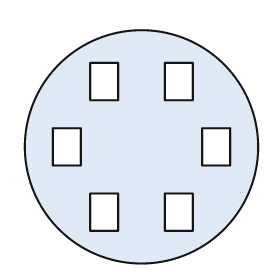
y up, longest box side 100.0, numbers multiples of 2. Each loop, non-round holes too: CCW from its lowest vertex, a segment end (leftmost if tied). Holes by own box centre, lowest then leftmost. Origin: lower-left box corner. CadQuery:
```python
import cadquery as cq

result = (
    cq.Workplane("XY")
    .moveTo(50.0, 50.0)
    .circle(50.0)
    .moveTo(28.0, 14.0)
    .lineTo(40.0, 14.0)
    .lineTo(40.0, 30.0)
    .lineTo(28.0, 30.0)
    .close()
    .moveTo(60.0, 14.0)
    .lineTo(72.0, 14.0)
    .lineTo(72.0, 30.0)
    .lineTo(60.0, 30.0)
    .close()
    .moveTo(12.0, 42.0)
    .lineTo(24.0, 42.0)
    .lineTo(24.0, 58.0)
    .lineTo(12.0, 58.0)
    .close()
    .moveTo(76.0, 42.0)
    .lineTo(88.0, 42.0)
    .lineTo(88.0, 58.0)
    .lineTo(76.0, 58.0)
    .close()
    .moveTo(28.0, 70.0)
    .lineTo(40.0, 70.0)
    .lineTo(40.0, 86.0)
    .lineTo(28.0, 86.0)
    .close()
    .moveTo(60.0, 70.0)
    .lineTo(72.0, 70.0)
    .lineTo(72.0, 86.0)
    .lineTo(60.0, 86.0)
    .close()
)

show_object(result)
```